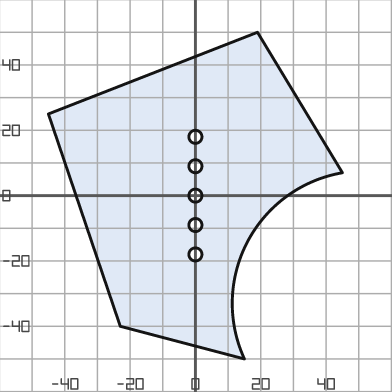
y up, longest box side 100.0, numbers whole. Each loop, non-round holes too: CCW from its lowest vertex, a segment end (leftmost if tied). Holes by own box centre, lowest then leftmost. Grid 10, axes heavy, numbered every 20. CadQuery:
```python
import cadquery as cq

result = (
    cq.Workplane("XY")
    .moveTo(15.0, -50.0)
    .threePointArc((16.0, -14.0), (45.0, 7.0))
    .lineTo(19.0, 50.0)
    .lineTo(-45.0, 25.0)
    .lineTo(-23.0, -40.0)
    .close()
    .moveTo(0.0, -18.0)
    .circle(2.0)
    .moveTo(0.0, -9.0)
    .circle(2.0)
    .moveTo(0.0, 0.0)
    .circle(2.0)
    .moveTo(0.0, 9.0)
    .circle(2.0)
    .moveTo(0.0, 18.0)
    .circle(2.0)
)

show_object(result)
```